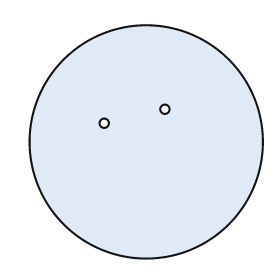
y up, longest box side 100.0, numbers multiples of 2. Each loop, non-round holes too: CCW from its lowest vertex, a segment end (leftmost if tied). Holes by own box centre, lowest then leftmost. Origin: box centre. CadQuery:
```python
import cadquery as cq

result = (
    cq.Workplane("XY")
    .moveTo(0.0, 0.0)
    .circle(50.0)
    .moveTo(-18.0, 8.0)
    .circle(2.0)
    .moveTo(8.0, 14.0)
    .circle(2.0)
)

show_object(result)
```